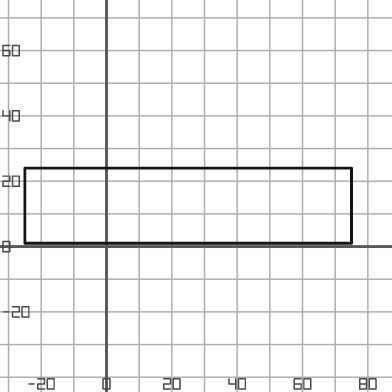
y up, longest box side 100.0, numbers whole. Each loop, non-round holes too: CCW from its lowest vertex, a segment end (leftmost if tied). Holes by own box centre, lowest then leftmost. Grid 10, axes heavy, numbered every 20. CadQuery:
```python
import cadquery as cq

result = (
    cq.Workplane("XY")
    .moveTo(-25.0, 1.0)
    .lineTo(75.0, 1.0)
    .lineTo(75.0, 24.0)
    .lineTo(-25.0, 24.0)
    .close()
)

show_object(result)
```